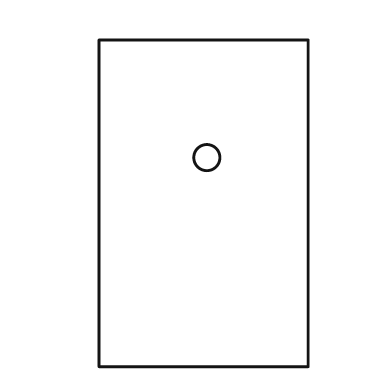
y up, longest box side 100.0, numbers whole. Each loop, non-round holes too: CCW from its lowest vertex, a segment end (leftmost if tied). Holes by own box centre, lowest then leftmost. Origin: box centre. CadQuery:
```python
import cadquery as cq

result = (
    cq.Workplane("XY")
    .moveTo(-32.0, -50.0)
    .lineTo(32.0, -50.0)
    .lineTo(32.0, 50.0)
    .lineTo(-32.0, 50.0)
    .close()
    .moveTo(1.0, 14.0)
    .circle(4.0)
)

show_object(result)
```